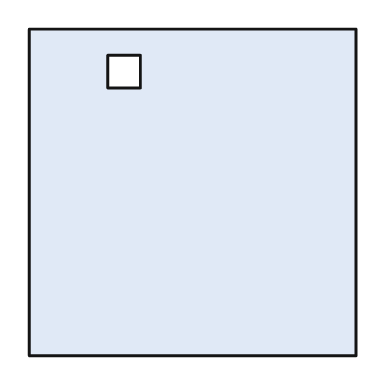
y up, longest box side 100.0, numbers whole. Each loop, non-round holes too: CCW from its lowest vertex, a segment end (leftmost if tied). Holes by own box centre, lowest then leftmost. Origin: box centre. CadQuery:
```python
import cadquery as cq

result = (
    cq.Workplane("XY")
    .moveTo(-50.0, -50.0)
    .lineTo(50.0, -50.0)
    .lineTo(50.0, 50.0)
    .lineTo(-50.0, 50.0)
    .close()
    .moveTo(-26.0, 32.0)
    .lineTo(-16.0, 32.0)
    .lineTo(-16.0, 42.0)
    .lineTo(-26.0, 42.0)
    .close()
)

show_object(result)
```